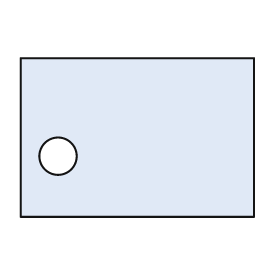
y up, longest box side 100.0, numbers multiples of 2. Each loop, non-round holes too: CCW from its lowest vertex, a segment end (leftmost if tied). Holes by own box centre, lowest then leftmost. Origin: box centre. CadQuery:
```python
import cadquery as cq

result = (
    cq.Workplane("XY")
    .moveTo(-50.0, -34.0)
    .lineTo(50.0, -34.0)
    .lineTo(50.0, 34.0)
    .lineTo(-50.0, 34.0)
    .close()
    .moveTo(-34.0, -8.0)
    .circle(8.0)
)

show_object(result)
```